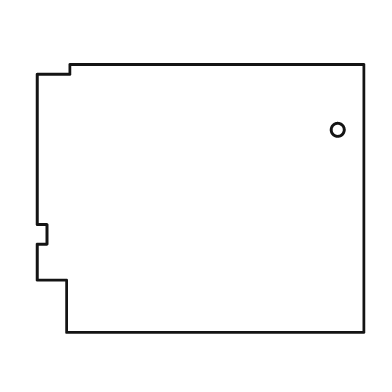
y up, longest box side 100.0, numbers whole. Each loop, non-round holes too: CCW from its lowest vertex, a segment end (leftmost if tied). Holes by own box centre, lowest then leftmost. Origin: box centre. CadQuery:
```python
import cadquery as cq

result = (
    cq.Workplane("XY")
    .moveTo(-41.0, -41.0)
    .lineTo(50.0, -41.0)
    .lineTo(50.0, 41.0)
    .lineTo(-40.0, 41.0)
    .lineTo(-40.0, 38.0)
    .lineTo(-50.0, 38.0)
    .lineTo(-50.0, -8.0)
    .lineTo(-47.0, -8.0)
    .lineTo(-47.0, -14.0)
    .lineTo(-50.0, -14.0)
    .lineTo(-50.0, -25.0)
    .lineTo(-41.0, -25.0)
    .close()
    .moveTo(42.0, 21.0)
    .circle(2.0)
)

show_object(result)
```